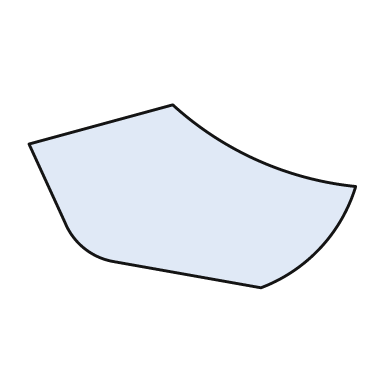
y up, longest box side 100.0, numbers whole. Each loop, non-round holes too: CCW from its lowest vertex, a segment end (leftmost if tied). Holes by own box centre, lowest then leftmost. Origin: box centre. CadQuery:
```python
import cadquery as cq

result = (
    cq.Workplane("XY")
    .moveTo(21.0, -28.0)
    .threePointArc((39.0, -16.0), (50.0, 3.0))
    .threePointArc((20.0, 11.0), (-6.0, 28.0))
    .lineTo(-50.0, 16.0)
    .lineTo(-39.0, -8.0)
    .threePointArc((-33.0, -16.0), (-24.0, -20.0))
    .close()
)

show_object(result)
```